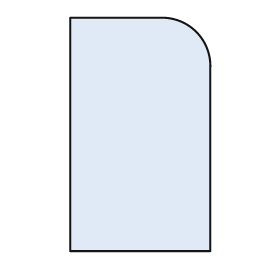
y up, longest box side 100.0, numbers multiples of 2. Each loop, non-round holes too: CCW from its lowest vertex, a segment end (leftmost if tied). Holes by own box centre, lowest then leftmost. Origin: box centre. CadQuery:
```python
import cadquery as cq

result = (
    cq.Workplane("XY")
    .moveTo(-30.0, -50.0)
    .lineTo(30.0, -50.0)
    .lineTo(30.0, 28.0)
    .threePointArc((24.0, 44.0), (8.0, 50.0))
    .lineTo(-30.0, 50.0)
    .close()
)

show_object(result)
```